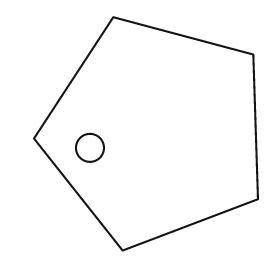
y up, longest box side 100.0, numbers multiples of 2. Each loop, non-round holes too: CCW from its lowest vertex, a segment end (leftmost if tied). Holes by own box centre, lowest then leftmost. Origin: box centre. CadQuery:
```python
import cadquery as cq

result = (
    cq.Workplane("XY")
    .moveTo(-10.0, -50.0)
    .lineTo(48.0, -28.0)
    .lineTo(46.0, 34.0)
    .lineTo(-14.0, 50.0)
    .lineTo(-48.0, -2.0)
    .close()
    .moveTo(-24.0, -6.0)
    .circle(6.0)
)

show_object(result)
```